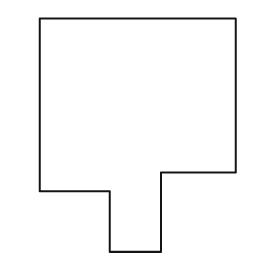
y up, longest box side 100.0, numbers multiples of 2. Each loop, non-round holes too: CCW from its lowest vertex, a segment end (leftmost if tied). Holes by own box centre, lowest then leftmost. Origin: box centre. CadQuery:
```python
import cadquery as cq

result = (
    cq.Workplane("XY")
    .moveTo(-12.0, -50.0)
    .lineTo(10.0, -50.0)
    .lineTo(10.0, -16.0)
    .lineTo(42.0, -16.0)
    .lineTo(42.0, 50.0)
    .lineTo(-42.0, 50.0)
    .lineTo(-42.0, -24.0)
    .lineTo(-12.0, -24.0)
    .close()
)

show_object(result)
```